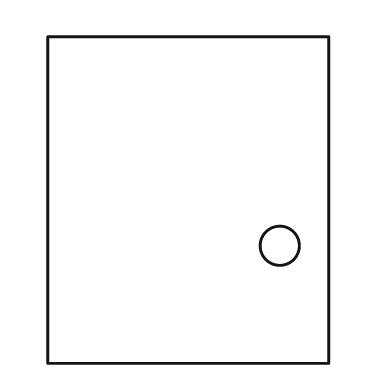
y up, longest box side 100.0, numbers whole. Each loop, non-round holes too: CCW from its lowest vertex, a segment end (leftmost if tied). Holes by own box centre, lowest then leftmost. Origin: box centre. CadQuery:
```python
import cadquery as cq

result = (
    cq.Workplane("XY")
    .moveTo(-43.0, -50.0)
    .lineTo(43.0, -50.0)
    .lineTo(43.0, 50.0)
    .lineTo(-43.0, 50.0)
    .close()
    .moveTo(28.0, -14.0)
    .circle(6.0)
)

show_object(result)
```